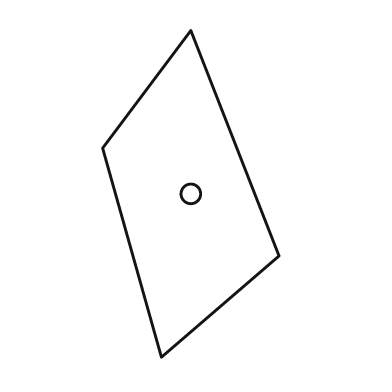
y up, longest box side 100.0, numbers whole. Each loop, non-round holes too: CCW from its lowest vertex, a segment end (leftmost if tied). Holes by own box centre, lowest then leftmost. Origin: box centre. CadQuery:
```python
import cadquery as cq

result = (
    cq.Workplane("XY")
    .moveTo(-9.0, -50.0)
    .lineTo(27.0, -19.0)
    .lineTo(0.0, 50.0)
    .lineTo(-27.0, 14.0)
    .close()
    .moveTo(0.0, 0.0)
    .circle(3.0)
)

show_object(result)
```